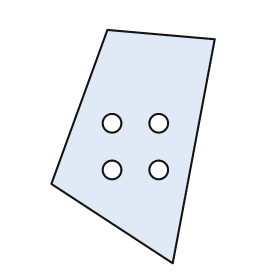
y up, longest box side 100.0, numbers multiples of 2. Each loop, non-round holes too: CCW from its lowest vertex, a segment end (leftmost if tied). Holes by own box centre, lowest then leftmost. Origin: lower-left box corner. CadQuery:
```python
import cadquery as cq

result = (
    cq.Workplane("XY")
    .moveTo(52.0, 0.0)
    .lineTo(70.0, 96.0)
    .lineTo(24.0, 100.0)
    .lineTo(0.0, 34.0)
    .close()
    .moveTo(26.0, 40.0)
    .circle(4.0)
    .moveTo(46.0, 40.0)
    .circle(4.0)
    .moveTo(26.0, 60.0)
    .circle(4.0)
    .moveTo(46.0, 60.0)
    .circle(4.0)
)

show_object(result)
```